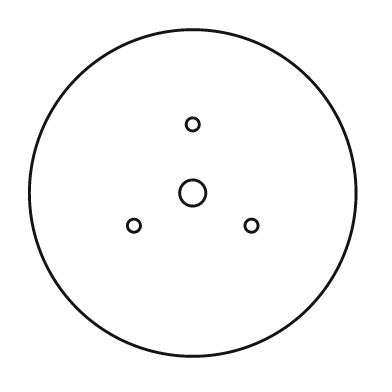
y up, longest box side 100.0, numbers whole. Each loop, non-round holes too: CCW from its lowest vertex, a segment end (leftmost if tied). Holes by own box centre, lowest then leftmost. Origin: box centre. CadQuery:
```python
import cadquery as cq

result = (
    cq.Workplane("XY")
    .moveTo(0.0, 0.0)
    .circle(50.0)
    .moveTo(-18.0, -10.0)
    .circle(2.0)
    .moveTo(18.0, -10.0)
    .circle(2.0)
    .moveTo(0.0, 0.0)
    .circle(4.0)
    .moveTo(0.0, 21.0)
    .circle(2.0)
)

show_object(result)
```